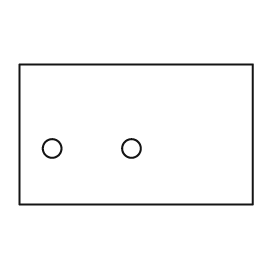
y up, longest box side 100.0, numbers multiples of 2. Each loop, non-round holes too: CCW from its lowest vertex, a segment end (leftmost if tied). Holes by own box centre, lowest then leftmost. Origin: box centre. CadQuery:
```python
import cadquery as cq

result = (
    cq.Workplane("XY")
    .moveTo(-50.0, -30.0)
    .lineTo(50.0, -30.0)
    .lineTo(50.0, 30.0)
    .lineTo(-50.0, 30.0)
    .close()
    .moveTo(-36.0, -6.0)
    .circle(4.0)
    .moveTo(-2.0, -6.0)
    .circle(4.0)
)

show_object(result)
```